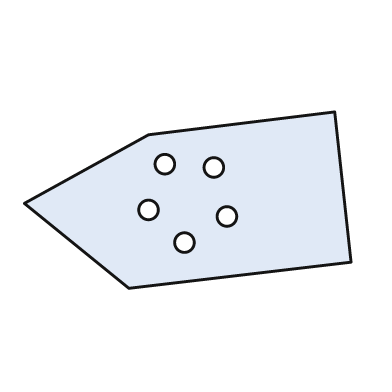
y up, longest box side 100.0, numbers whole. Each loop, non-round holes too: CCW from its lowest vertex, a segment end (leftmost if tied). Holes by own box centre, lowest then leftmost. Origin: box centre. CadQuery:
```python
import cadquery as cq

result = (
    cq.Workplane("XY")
    .moveTo(-18.0, -27.0)
    .lineTo(50.0, -19.0)
    .lineTo(45.0, 27.0)
    .lineTo(-12.0, 20.0)
    .lineTo(-50.0, -1.0)
    .close()
    .moveTo(-1.0, -13.0)
    .circle(3.0)
    .moveTo(12.0, -5.0)
    .circle(3.0)
    .moveTo(-12.0, -3.0)
    .circle(3.0)
    .moveTo(8.0, 10.0)
    .circle(3.0)
    .moveTo(-7.0, 11.0)
    .circle(3.0)
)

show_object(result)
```